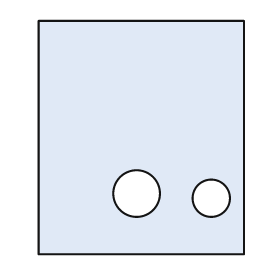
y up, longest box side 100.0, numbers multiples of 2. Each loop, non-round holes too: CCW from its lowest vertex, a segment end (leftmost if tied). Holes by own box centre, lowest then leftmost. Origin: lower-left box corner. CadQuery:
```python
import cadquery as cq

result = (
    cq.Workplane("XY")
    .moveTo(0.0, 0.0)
    .lineTo(88.0, 0.0)
    .lineTo(88.0, 100.0)
    .lineTo(0.0, 100.0)
    .close()
    .moveTo(74.0, 24.0)
    .circle(8.0)
    .moveTo(42.0, 26.0)
    .circle(10.0)
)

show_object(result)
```